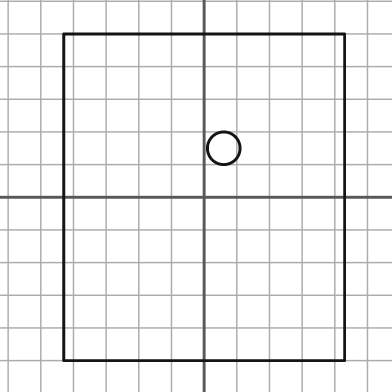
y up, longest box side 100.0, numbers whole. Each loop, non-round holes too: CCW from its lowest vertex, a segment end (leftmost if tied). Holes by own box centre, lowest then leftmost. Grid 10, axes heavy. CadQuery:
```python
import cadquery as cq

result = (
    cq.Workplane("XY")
    .moveTo(-43.0, -50.0)
    .lineTo(43.0, -50.0)
    .lineTo(43.0, 50.0)
    .lineTo(-43.0, 50.0)
    .close()
    .moveTo(6.0, 15.0)
    .circle(5.0)
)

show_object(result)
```